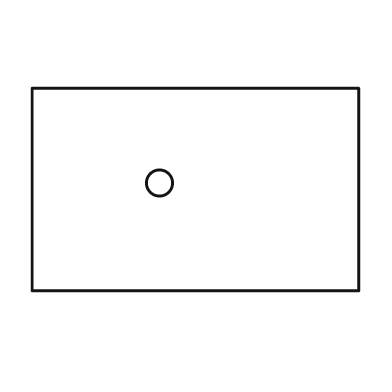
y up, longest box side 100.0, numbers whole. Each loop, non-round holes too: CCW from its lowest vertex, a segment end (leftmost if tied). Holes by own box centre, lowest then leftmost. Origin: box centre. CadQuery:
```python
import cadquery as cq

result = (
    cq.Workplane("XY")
    .moveTo(-50.0, -31.0)
    .lineTo(50.0, -31.0)
    .lineTo(50.0, 31.0)
    .lineTo(-50.0, 31.0)
    .close()
    .moveTo(-11.0, 2.0)
    .circle(4.0)
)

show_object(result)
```